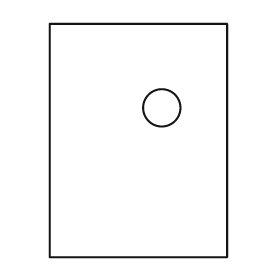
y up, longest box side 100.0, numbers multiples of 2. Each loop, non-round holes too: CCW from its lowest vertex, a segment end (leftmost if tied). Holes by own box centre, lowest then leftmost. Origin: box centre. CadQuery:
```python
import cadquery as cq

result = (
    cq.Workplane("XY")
    .moveTo(-38.0, -50.0)
    .lineTo(38.0, -50.0)
    .lineTo(38.0, 50.0)
    .lineTo(-38.0, 50.0)
    .close()
    .moveTo(10.0, 14.0)
    .circle(8.0)
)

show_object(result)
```